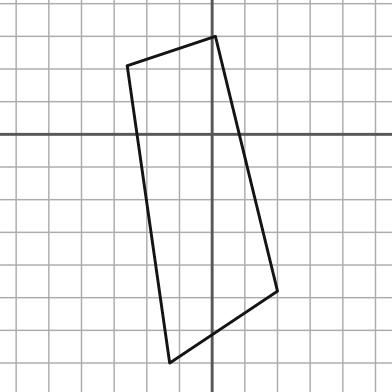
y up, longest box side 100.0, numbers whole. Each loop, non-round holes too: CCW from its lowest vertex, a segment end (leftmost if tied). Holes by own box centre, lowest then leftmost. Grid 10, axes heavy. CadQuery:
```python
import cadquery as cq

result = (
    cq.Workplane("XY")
    .moveTo(-13.0, -70.0)
    .lineTo(20.0, -48.0)
    .lineTo(1.0, 30.0)
    .lineTo(-26.0, 21.0)
    .close()
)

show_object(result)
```